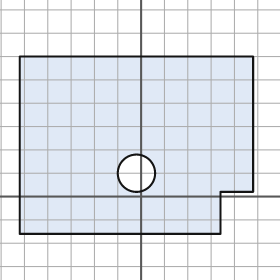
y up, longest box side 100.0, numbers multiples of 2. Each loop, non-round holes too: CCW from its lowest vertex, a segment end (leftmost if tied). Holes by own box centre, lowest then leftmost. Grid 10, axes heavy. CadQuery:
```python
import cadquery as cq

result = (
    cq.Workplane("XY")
    .moveTo(-52.0, -16.0)
    .lineTo(34.0, -16.0)
    .lineTo(34.0, 2.0)
    .lineTo(48.0, 2.0)
    .lineTo(48.0, 60.0)
    .lineTo(-52.0, 60.0)
    .close()
    .moveTo(-2.0, 10.0)
    .circle(8.0)
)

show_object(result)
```